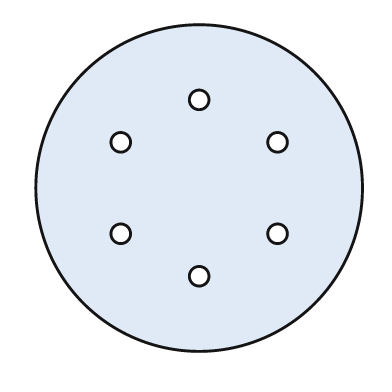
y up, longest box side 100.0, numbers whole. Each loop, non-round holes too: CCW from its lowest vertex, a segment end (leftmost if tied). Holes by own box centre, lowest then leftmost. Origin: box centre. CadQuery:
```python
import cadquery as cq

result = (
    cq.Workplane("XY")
    .moveTo(0.0, 0.0)
    .circle(50.0)
    .moveTo(0.0, -27.0)
    .circle(3.0)
    .moveTo(-24.0, -14.0)
    .circle(3.0)
    .moveTo(24.0, -14.0)
    .circle(3.0)
    .moveTo(-24.0, 14.0)
    .circle(3.0)
    .moveTo(24.0, 14.0)
    .circle(3.0)
    .moveTo(0.0, 27.0)
    .circle(3.0)
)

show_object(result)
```